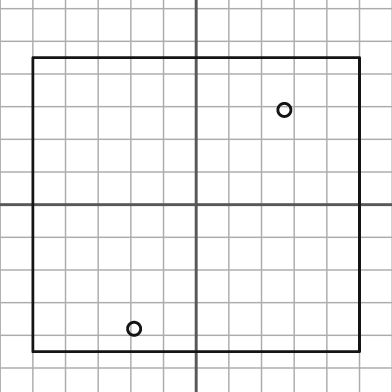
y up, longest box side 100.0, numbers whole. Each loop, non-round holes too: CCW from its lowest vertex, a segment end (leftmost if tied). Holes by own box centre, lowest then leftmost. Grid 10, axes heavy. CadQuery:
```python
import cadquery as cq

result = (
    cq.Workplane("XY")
    .moveTo(-50.0, -45.0)
    .lineTo(50.0, -45.0)
    .lineTo(50.0, 45.0)
    .lineTo(-50.0, 45.0)
    .close()
    .moveTo(-19.0, -38.0)
    .circle(2.0)
    .moveTo(27.0, 29.0)
    .circle(2.0)
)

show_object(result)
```